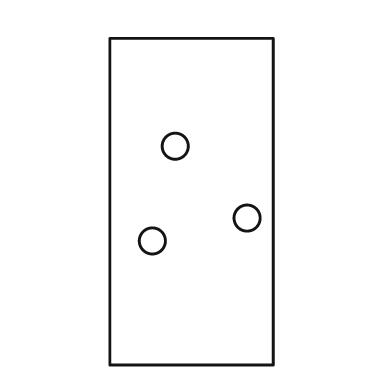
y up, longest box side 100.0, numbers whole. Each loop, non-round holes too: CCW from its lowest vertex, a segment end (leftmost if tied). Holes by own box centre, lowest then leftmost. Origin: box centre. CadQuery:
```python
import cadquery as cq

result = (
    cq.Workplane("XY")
    .moveTo(-25.0, -50.0)
    .lineTo(25.0, -50.0)
    .lineTo(25.0, 50.0)
    .lineTo(-25.0, 50.0)
    .close()
    .moveTo(-12.0, -12.0)
    .circle(4.0)
    .moveTo(17.0, -5.0)
    .circle(4.0)
    .moveTo(-5.0, 17.0)
    .circle(4.0)
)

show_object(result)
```